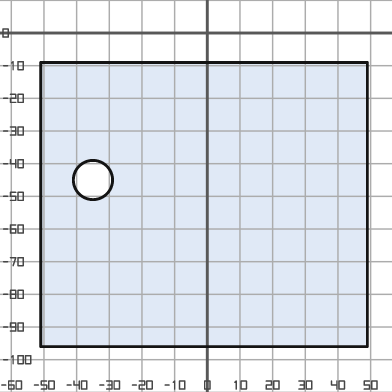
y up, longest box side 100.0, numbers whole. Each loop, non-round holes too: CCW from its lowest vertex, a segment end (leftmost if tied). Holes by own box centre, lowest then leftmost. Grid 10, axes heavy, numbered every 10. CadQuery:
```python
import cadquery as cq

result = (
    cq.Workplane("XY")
    .moveTo(-51.0, -96.0)
    .lineTo(49.0, -96.0)
    .lineTo(49.0, -9.0)
    .lineTo(-51.0, -9.0)
    .close()
    .moveTo(-35.0, -45.0)
    .circle(6.0)
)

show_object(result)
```